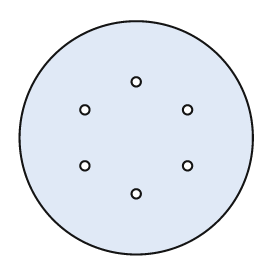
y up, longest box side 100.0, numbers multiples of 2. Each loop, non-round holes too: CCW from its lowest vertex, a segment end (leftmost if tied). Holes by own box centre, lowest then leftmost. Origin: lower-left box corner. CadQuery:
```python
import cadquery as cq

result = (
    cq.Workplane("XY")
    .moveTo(50.0, 50.0)
    .circle(50.0)
    .moveTo(50.0, 26.0)
    .circle(2.0)
    .moveTo(28.0, 38.0)
    .circle(2.0)
    .moveTo(72.0, 38.0)
    .circle(2.0)
    .moveTo(28.0, 62.0)
    .circle(2.0)
    .moveTo(72.0, 62.0)
    .circle(2.0)
    .moveTo(50.0, 74.0)
    .circle(2.0)
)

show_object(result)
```